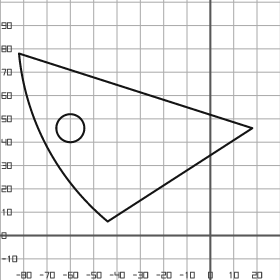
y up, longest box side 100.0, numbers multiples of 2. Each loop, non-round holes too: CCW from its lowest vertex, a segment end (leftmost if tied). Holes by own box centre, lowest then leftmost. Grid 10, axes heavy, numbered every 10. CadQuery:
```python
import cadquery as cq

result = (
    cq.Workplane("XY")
    .moveTo(-44.0, 6.0)
    .lineTo(18.0, 46.0)
    .lineTo(-82.0, 78.0)
    .threePointArc((-70.0, 38.0), (-44.0, 6.0))
    .close()
    .moveTo(-60.0, 46.0)
    .circle(6.0)
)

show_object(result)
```